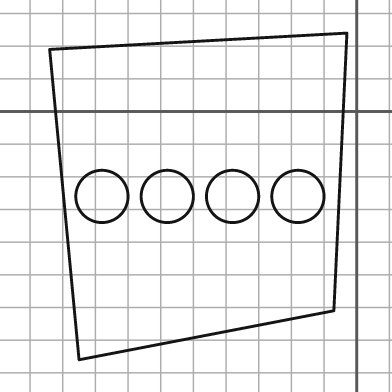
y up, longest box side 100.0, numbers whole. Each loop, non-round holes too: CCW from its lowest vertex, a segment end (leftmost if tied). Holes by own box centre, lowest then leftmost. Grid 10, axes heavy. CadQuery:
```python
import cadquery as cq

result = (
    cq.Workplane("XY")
    .moveTo(-85.0, -76.0)
    .lineTo(-7.0, -61.0)
    .lineTo(-3.0, 24.0)
    .lineTo(-94.0, 19.0)
    .close()
    .moveTo(-78.0, -26.0)
    .circle(8.0)
    .moveTo(-58.0, -26.0)
    .circle(8.0)
    .moveTo(-38.0, -26.0)
    .circle(8.0)
    .moveTo(-18.0, -26.0)
    .circle(8.0)
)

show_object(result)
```